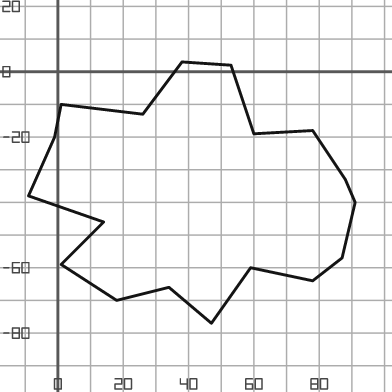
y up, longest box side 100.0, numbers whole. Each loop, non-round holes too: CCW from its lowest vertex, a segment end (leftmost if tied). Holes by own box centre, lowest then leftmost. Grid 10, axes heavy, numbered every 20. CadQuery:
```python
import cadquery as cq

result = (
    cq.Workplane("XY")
    .moveTo(47.0, -77.0)
    .lineTo(59.0, -60.0)
    .lineTo(78.0, -64.0)
    .lineTo(87.0, -57.0)
    .lineTo(91.0, -40.0)
    .lineTo(88.0, -33.0)
    .lineTo(78.0, -18.0)
    .lineTo(60.0, -19.0)
    .lineTo(53.0, 2.0)
    .lineTo(38.0, 3.0)
    .lineTo(26.0, -13.0)
    .lineTo(1.0, -10.0)
    .lineTo(-1.0, -20.0)
    .lineTo(-9.0, -38.0)
    .lineTo(14.0, -46.0)
    .lineTo(1.0, -59.0)
    .lineTo(18.0, -70.0)
    .lineTo(34.0, -66.0)
    .close()
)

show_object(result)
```